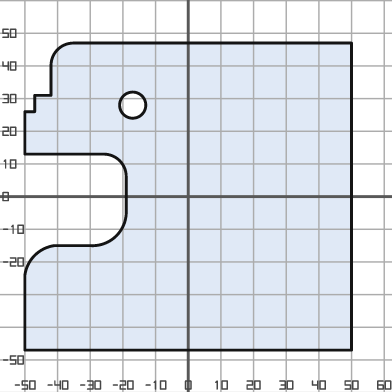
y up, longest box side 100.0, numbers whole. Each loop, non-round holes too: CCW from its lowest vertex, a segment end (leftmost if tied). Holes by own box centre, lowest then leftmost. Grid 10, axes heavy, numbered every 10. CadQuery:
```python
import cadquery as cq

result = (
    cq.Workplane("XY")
    .moveTo(-50.0, -47.0)
    .lineTo(50.0, -47.0)
    .lineTo(50.0, 47.0)
    .lineTo(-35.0, 47.0)
    .threePointArc((-40.0, 45.0), (-42.0, 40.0))
    .lineTo(-42.0, 31.0)
    .lineTo(-47.0, 31.0)
    .lineTo(-47.0, 26.0)
    .lineTo(-50.0, 26.0)
    .lineTo(-50.0, 13.0)
    .lineTo(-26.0, 13.0)
    .threePointArc((-21.0, 11.0), (-19.0, 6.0))
    .lineTo(-19.0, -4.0)
    .threePointArc((-22.0, -12.0), (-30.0, -15.0))
    .lineTo(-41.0, -15.0)
    .threePointArc((-47.0, -18.0), (-50.0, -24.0))
    .close()
    .moveTo(-17.0, 28.0)
    .circle(4.0)
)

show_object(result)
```